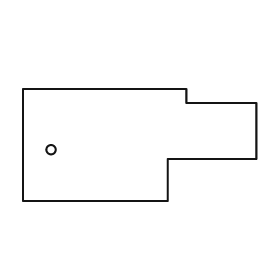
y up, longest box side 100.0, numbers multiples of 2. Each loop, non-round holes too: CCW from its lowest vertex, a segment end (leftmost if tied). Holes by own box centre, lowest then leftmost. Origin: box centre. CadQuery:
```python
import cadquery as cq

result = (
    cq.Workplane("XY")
    .moveTo(-50.0, -24.0)
    .lineTo(12.0, -24.0)
    .lineTo(12.0, -6.0)
    .lineTo(50.0, -6.0)
    .lineTo(50.0, 18.0)
    .lineTo(20.0, 18.0)
    .lineTo(20.0, 24.0)
    .lineTo(-50.0, 24.0)
    .close()
    .moveTo(-38.0, -2.0)
    .circle(2.0)
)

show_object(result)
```